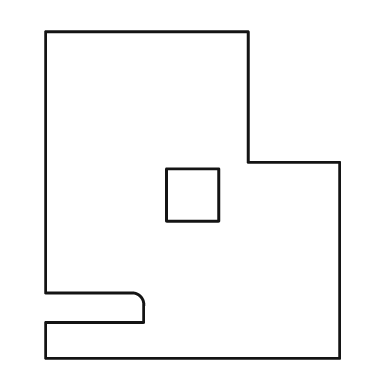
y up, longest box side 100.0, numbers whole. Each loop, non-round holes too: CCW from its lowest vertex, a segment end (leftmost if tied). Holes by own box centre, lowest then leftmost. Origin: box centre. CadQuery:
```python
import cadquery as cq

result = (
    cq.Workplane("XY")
    .moveTo(-45.0, -50.0)
    .lineTo(45.0, -50.0)
    .lineTo(45.0, 10.0)
    .lineTo(17.0, 10.0)
    .lineTo(17.0, 50.0)
    .lineTo(-45.0, 50.0)
    .lineTo(-45.0, -30.0)
    .lineTo(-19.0, -30.0)
    .threePointArc((-16.0, -31.0), (-15.0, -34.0))
    .lineTo(-15.0, -39.0)
    .lineTo(-45.0, -39.0)
    .close()
    .moveTo(-8.0, -8.0)
    .lineTo(8.0, -8.0)
    .lineTo(8.0, 8.0)
    .lineTo(-8.0, 8.0)
    .close()
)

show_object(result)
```